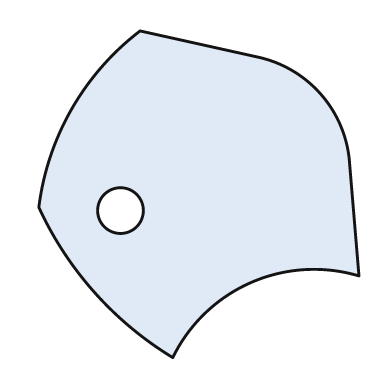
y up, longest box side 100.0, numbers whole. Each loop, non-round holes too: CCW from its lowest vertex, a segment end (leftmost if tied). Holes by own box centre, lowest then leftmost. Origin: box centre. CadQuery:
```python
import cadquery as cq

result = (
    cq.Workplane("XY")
    .moveTo(-8.0, -50.0)
    .threePointArc((16.0, -27.0), (49.0, -25.0))
    .lineTo(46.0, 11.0)
    .threePointArc((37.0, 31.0), (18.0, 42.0))
    .lineTo(-18.0, 50.0)
    .threePointArc((-39.0, 26.0), (-49.0, -4.0))
    .threePointArc((-32.0, -30.0), (-8.0, -50.0))
    .close()
    .moveTo(-24.0, -5.0)
    .circle(7.0)
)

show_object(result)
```